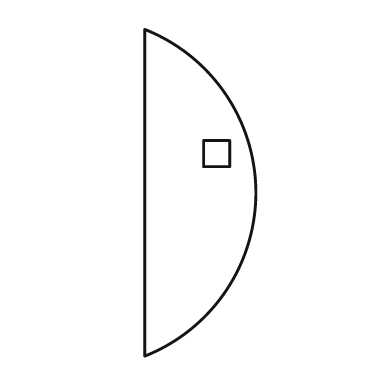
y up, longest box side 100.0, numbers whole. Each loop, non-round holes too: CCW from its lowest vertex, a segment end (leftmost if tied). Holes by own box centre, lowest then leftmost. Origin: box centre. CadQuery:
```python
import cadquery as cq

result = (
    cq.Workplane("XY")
    .moveTo(-17.0, -50.0)
    .threePointArc((17.0, 0.0), (-17.0, 50.0))
    .close()
    .moveTo(1.0, 8.0)
    .lineTo(9.0, 8.0)
    .lineTo(9.0, 16.0)
    .lineTo(1.0, 16.0)
    .close()
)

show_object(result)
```